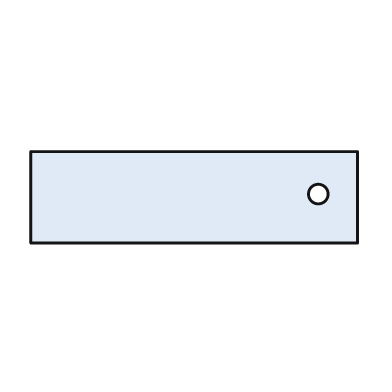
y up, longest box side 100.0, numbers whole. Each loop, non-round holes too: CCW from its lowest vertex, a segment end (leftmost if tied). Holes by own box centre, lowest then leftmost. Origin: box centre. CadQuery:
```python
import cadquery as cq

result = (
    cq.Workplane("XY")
    .moveTo(-50.0, -14.0)
    .lineTo(50.0, -14.0)
    .lineTo(50.0, 14.0)
    .lineTo(-50.0, 14.0)
    .close()
    .moveTo(38.0, 1.0)
    .circle(3.0)
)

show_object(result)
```